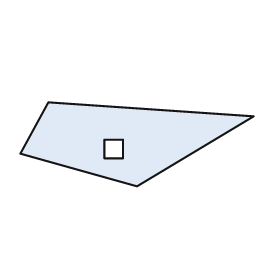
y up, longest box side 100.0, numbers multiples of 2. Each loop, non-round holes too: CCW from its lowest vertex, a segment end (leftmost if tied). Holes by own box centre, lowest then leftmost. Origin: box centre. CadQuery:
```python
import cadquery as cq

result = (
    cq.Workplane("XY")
    .moveTo(0.0, -18.0)
    .lineTo(50.0, 12.0)
    .lineTo(-38.0, 18.0)
    .lineTo(-50.0, -4.0)
    .close()
    .moveTo(-14.0, -6.0)
    .lineTo(-6.0, -6.0)
    .lineTo(-6.0, 2.0)
    .lineTo(-14.0, 2.0)
    .close()
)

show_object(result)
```